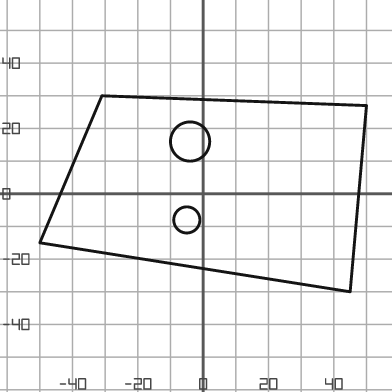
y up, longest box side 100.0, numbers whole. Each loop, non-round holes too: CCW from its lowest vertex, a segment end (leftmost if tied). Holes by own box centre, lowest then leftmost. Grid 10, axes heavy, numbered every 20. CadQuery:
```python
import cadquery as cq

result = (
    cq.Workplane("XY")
    .moveTo(45.0, -30.0)
    .lineTo(50.0, 27.0)
    .lineTo(-31.0, 30.0)
    .lineTo(-50.0, -15.0)
    .close()
    .moveTo(-5.0, -8.0)
    .circle(4.0)
    .moveTo(-4.0, 16.0)
    .circle(6.0)
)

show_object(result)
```